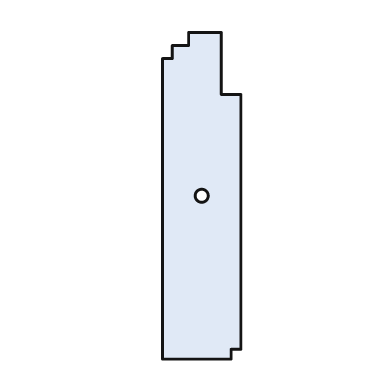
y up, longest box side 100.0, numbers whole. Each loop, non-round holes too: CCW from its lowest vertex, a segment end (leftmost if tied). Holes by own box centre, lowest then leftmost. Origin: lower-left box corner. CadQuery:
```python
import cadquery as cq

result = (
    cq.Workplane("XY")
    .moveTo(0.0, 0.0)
    .lineTo(21.0, 0.0)
    .lineTo(21.0, 3.0)
    .lineTo(24.0, 3.0)
    .lineTo(24.0, 81.0)
    .lineTo(18.0, 81.0)
    .lineTo(18.0, 100.0)
    .lineTo(8.0, 100.0)
    .lineTo(8.0, 96.0)
    .lineTo(3.0, 96.0)
    .lineTo(3.0, 92.0)
    .lineTo(0.0, 92.0)
    .close()
    .moveTo(12.0, 50.0)
    .circle(2.0)
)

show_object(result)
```